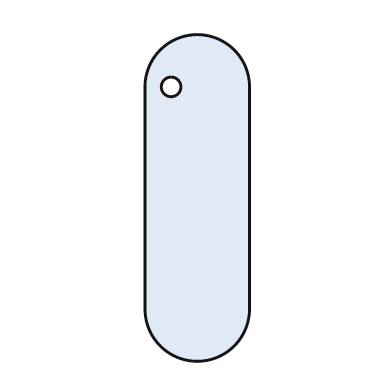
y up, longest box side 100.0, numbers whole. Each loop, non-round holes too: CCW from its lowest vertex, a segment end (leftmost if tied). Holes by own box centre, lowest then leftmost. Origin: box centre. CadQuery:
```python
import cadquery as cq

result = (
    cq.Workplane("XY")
    .moveTo(-16.0, -34.0)
    .threePointArc((0.0, -50.0), (16.0, -34.0))
    .lineTo(16.0, 34.0)
    .threePointArc((0.0, 50.0), (-16.0, 34.0))
    .close()
    .moveTo(-8.0, 34.0)
    .circle(3.0)
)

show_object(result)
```